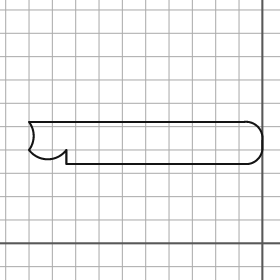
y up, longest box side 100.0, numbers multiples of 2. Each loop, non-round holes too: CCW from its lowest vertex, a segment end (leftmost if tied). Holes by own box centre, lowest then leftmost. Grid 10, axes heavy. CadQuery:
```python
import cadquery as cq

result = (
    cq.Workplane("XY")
    .moveTo(-84.0, 34.0)
    .lineTo(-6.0, 34.0)
    .threePointArc((-2.0, 36.0), (0.0, 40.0))
    .lineTo(0.0, 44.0)
    .threePointArc((-2.0, 50.0), (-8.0, 52.0))
    .lineTo(-100.0, 52.0)
    .threePointArc((-98.0, 46.0), (-100.0, 40.0))
    .threePointArc((-92.0, 36.0), (-84.0, 40.0))
    .close()
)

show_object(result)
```